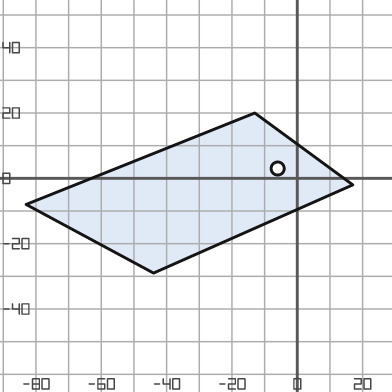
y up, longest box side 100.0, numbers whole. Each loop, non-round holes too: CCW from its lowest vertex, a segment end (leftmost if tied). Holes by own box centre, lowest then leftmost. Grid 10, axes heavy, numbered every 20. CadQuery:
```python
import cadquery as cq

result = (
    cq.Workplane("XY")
    .moveTo(-44.0, -29.0)
    .lineTo(17.0, -2.0)
    .lineTo(-13.0, 20.0)
    .lineTo(-83.0, -8.0)
    .close()
    .moveTo(-6.0, 3.0)
    .circle(2.0)
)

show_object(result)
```